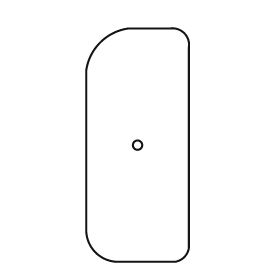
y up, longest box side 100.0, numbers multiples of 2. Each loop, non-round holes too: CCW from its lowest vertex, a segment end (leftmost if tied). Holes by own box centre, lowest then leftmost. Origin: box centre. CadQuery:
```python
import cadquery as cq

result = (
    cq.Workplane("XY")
    .moveTo(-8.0, -50.0)
    .lineTo(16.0, -50.0)
    .threePointArc((20.0, -48.0), (22.0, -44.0))
    .lineTo(22.0, 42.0)
    .threePointArc((20.0, 48.0), (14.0, 50.0))
    .lineTo(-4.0, 50.0)
    .threePointArc((-16.0, 44.0), (-22.0, 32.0))
    .lineTo(-22.0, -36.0)
    .threePointArc((-18.0, -46.0), (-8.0, -50.0))
    .close()
    .moveTo(0.0, 0.0)
    .circle(2.0)
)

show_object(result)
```